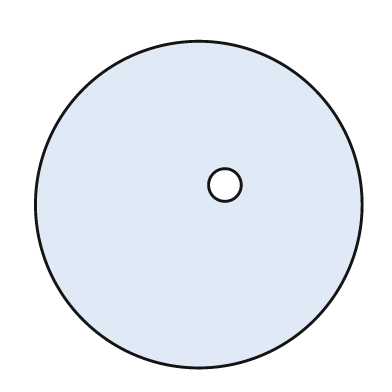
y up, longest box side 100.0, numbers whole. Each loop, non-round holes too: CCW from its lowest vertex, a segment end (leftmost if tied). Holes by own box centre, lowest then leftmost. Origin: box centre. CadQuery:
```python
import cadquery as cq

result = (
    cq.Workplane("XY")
    .moveTo(0.0, 0.0)
    .circle(50.0)
    .moveTo(8.0, 6.0)
    .circle(5.0)
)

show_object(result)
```